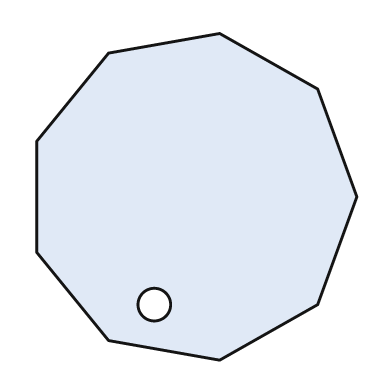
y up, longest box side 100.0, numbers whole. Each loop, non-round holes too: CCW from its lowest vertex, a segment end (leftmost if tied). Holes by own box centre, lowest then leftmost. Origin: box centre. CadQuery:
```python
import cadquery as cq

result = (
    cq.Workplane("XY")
    .moveTo(7.0, -50.0)
    .lineTo(37.0, -33.0)
    .lineTo(49.0, 0.0)
    .lineTo(37.0, 33.0)
    .lineTo(7.0, 50.0)
    .lineTo(-27.0, 44.0)
    .lineTo(-49.0, 17.0)
    .lineTo(-49.0, -17.0)
    .lineTo(-27.0, -44.0)
    .close()
    .moveTo(-13.0, -33.0)
    .circle(5.0)
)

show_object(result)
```